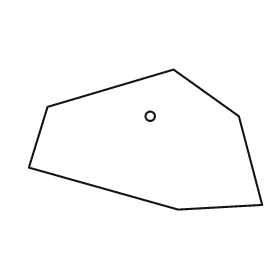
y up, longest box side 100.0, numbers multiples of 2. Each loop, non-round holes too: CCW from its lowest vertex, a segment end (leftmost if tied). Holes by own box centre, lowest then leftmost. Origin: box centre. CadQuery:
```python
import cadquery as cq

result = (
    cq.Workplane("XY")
    .moveTo(14.0, -30.0)
    .lineTo(50.0, -28.0)
    .lineTo(40.0, 10.0)
    .lineTo(12.0, 30.0)
    .lineTo(-42.0, 14.0)
    .lineTo(-50.0, -12.0)
    .close()
    .moveTo(2.0, 10.0)
    .circle(2.0)
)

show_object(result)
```